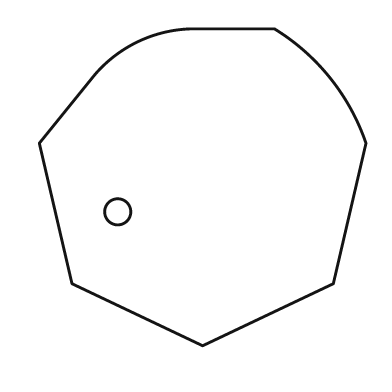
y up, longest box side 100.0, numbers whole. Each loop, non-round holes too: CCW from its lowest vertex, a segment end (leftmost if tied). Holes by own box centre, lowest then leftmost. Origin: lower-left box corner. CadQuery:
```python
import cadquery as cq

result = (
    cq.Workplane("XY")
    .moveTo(50.0, 0.0)
    .lineTo(90.0, 19.0)
    .lineTo(100.0, 62.0)
    .threePointArc((89.0, 82.0), (72.0, 97.0))
    .lineTo(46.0, 97.0)
    .threePointArc((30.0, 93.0), (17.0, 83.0))
    .lineTo(0.0, 62.0)
    .lineTo(10.0, 19.0)
    .close()
    .moveTo(24.0, 41.0)
    .circle(4.0)
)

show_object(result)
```